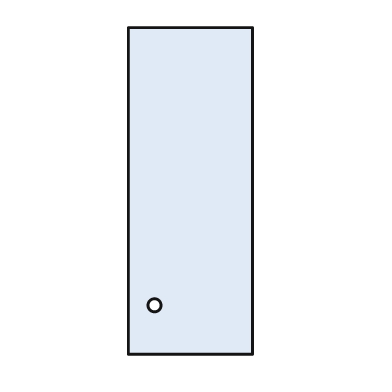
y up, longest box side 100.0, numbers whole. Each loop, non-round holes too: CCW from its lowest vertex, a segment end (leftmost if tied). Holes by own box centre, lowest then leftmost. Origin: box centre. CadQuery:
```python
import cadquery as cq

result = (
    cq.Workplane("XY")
    .moveTo(-19.0, -50.0)
    .lineTo(19.0, -50.0)
    .lineTo(19.0, 50.0)
    .lineTo(-19.0, 50.0)
    .close()
    .moveTo(-11.0, -35.0)
    .circle(2.0)
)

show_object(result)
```